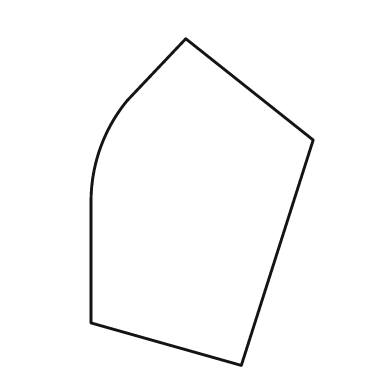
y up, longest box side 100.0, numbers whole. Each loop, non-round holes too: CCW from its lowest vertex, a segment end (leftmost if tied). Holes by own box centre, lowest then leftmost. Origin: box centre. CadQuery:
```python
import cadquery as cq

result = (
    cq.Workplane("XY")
    .moveTo(12.0, -50.0)
    .lineTo(34.0, 19.0)
    .lineTo(-5.0, 50.0)
    .lineTo(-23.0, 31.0)
    .threePointArc((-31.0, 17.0), (-34.0, 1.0))
    .lineTo(-34.0, -37.0)
    .close()
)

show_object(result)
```